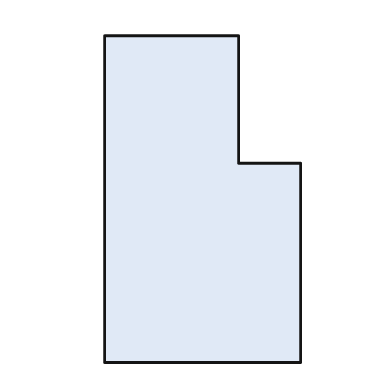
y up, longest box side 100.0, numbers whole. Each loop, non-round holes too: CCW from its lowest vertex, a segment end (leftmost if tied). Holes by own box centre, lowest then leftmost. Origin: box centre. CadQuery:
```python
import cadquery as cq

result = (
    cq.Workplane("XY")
    .moveTo(-30.0, -50.0)
    .lineTo(30.0, -50.0)
    .lineTo(30.0, 11.0)
    .lineTo(11.0, 11.0)
    .lineTo(11.0, 50.0)
    .lineTo(-30.0, 50.0)
    .close()
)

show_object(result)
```